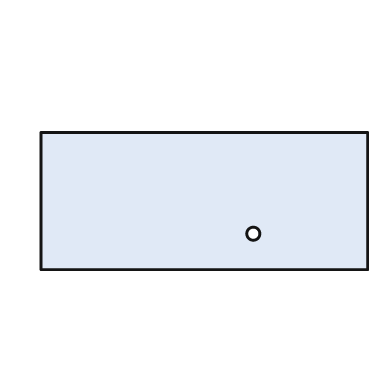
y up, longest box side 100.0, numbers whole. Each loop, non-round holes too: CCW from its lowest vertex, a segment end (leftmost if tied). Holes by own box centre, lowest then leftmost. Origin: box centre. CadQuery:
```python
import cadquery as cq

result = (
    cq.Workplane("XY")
    .moveTo(-50.0, -21.0)
    .lineTo(50.0, -21.0)
    .lineTo(50.0, 21.0)
    .lineTo(-50.0, 21.0)
    .close()
    .moveTo(15.0, -10.0)
    .circle(2.0)
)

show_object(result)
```